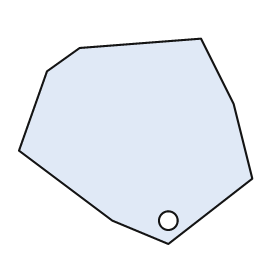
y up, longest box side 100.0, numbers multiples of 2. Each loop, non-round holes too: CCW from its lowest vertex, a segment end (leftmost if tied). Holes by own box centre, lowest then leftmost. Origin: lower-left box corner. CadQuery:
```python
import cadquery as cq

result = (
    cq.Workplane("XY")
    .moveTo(64.0, 0.0)
    .lineTo(100.0, 28.0)
    .lineTo(92.0, 60.0)
    .lineTo(78.0, 88.0)
    .lineTo(26.0, 84.0)
    .lineTo(12.0, 74.0)
    .lineTo(0.0, 40.0)
    .lineTo(40.0, 10.0)
    .close()
    .moveTo(64.0, 10.0)
    .circle(4.0)
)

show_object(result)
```